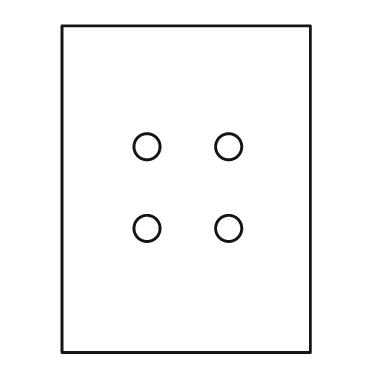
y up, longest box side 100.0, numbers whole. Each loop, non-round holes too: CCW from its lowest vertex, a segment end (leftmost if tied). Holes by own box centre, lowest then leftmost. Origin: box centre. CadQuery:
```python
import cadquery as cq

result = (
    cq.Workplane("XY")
    .moveTo(-38.0, -50.0)
    .lineTo(38.0, -50.0)
    .lineTo(38.0, 50.0)
    .lineTo(-38.0, 50.0)
    .close()
    .moveTo(-12.0, -12.0)
    .circle(4.0)
    .moveTo(13.0, -12.0)
    .circle(4.0)
    .moveTo(-12.0, 13.0)
    .circle(4.0)
    .moveTo(13.0, 13.0)
    .circle(4.0)
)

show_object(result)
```